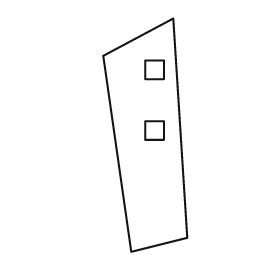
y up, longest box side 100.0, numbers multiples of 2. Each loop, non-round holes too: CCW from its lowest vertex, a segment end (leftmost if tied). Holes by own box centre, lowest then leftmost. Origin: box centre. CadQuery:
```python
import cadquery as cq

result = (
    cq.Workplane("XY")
    .moveTo(-6.0, -50.0)
    .lineTo(18.0, -44.0)
    .lineTo(12.0, 50.0)
    .lineTo(-18.0, 34.0)
    .close()
    .moveTo(0.0, -2.0)
    .lineTo(8.0, -2.0)
    .lineTo(8.0, 6.0)
    .lineTo(0.0, 6.0)
    .close()
    .moveTo(0.0, 24.0)
    .lineTo(8.0, 24.0)
    .lineTo(8.0, 32.0)
    .lineTo(0.0, 32.0)
    .close()
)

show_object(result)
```